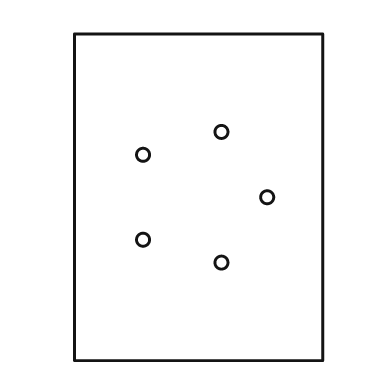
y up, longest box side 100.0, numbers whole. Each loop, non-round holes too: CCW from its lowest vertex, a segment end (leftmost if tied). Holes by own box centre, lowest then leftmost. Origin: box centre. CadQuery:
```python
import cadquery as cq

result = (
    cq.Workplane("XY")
    .moveTo(-38.0, -50.0)
    .lineTo(38.0, -50.0)
    .lineTo(38.0, 50.0)
    .lineTo(-38.0, 50.0)
    .close()
    .moveTo(7.0, -20.0)
    .circle(2.0)
    .moveTo(-17.0, -13.0)
    .circle(2.0)
    .moveTo(21.0, 0.0)
    .circle(2.0)
    .moveTo(-17.0, 13.0)
    .circle(2.0)
    .moveTo(7.0, 20.0)
    .circle(2.0)
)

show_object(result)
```